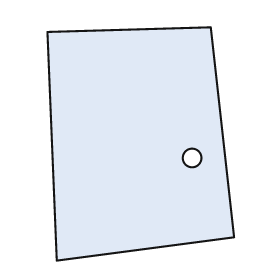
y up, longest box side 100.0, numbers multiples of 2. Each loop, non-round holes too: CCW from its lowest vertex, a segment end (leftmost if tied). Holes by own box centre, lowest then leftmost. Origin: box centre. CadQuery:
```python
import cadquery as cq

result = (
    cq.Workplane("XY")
    .moveTo(-36.0, -50.0)
    .lineTo(40.0, -40.0)
    .lineTo(30.0, 50.0)
    .lineTo(-40.0, 48.0)
    .close()
    .moveTo(22.0, -6.0)
    .circle(4.0)
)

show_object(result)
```